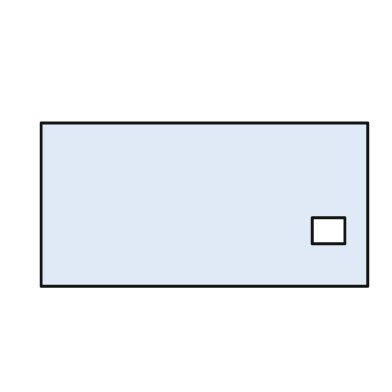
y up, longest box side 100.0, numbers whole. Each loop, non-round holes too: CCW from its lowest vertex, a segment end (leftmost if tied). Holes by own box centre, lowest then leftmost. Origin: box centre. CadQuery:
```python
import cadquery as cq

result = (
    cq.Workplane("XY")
    .moveTo(-50.0, -25.0)
    .lineTo(50.0, -25.0)
    .lineTo(50.0, 25.0)
    .lineTo(-50.0, 25.0)
    .close()
    .moveTo(33.0, -12.0)
    .lineTo(43.0, -12.0)
    .lineTo(43.0, -4.0)
    .lineTo(33.0, -4.0)
    .close()
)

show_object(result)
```